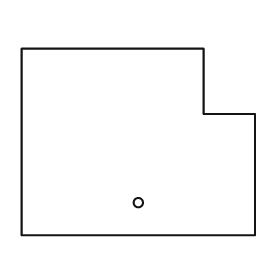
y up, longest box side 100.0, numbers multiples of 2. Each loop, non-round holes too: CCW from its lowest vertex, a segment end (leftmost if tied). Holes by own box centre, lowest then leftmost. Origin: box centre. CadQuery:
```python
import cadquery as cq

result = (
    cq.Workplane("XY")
    .moveTo(-50.0, -40.0)
    .lineTo(50.0, -40.0)
    .lineTo(50.0, 12.0)
    .lineTo(28.0, 12.0)
    .lineTo(28.0, 40.0)
    .lineTo(-50.0, 40.0)
    .close()
    .moveTo(0.0, -26.0)
    .circle(2.0)
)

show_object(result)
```